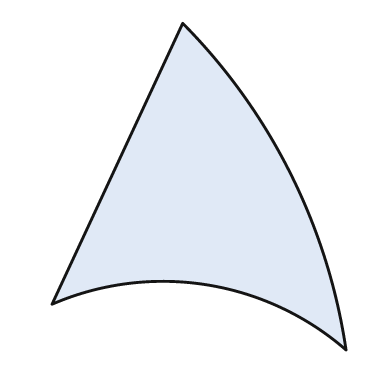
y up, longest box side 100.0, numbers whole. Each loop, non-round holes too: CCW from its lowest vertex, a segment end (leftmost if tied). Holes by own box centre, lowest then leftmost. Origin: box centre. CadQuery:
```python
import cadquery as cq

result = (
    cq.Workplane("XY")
    .moveTo(45.0, -50.0)
    .threePointArc((28.0, 4.0), (-5.0, 50.0))
    .lineTo(-45.0, -36.0)
    .threePointArc((2.0, -30.0), (45.0, -50.0))
    .close()
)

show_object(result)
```